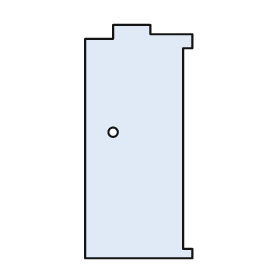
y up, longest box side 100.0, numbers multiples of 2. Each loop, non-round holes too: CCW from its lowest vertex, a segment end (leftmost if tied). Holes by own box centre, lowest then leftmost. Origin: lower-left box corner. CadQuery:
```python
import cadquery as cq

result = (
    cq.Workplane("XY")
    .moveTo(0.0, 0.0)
    .lineTo(46.0, 0.0)
    .lineTo(46.0, 4.0)
    .lineTo(42.0, 4.0)
    .lineTo(42.0, 90.0)
    .lineTo(46.0, 90.0)
    .lineTo(46.0, 96.0)
    .lineTo(28.0, 96.0)
    .lineTo(28.0, 100.0)
    .lineTo(12.0, 100.0)
    .lineTo(12.0, 94.0)
    .lineTo(0.0, 94.0)
    .close()
    .moveTo(12.0, 54.0)
    .circle(2.0)
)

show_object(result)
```